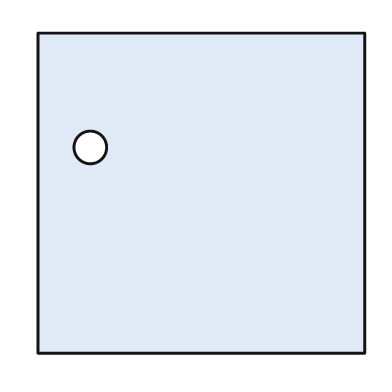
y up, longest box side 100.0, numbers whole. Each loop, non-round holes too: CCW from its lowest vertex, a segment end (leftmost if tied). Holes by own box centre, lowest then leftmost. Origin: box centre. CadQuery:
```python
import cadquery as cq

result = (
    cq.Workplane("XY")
    .moveTo(-50.0, -49.0)
    .lineTo(50.0, -49.0)
    .lineTo(50.0, 49.0)
    .lineTo(-50.0, 49.0)
    .close()
    .moveTo(-34.0, 14.0)
    .circle(5.0)
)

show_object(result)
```